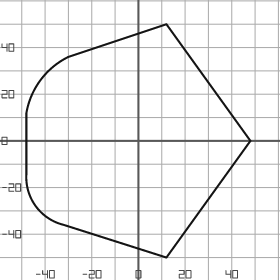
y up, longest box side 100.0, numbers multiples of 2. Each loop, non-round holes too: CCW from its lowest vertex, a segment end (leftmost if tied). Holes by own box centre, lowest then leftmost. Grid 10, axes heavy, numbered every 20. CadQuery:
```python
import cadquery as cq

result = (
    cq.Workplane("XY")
    .moveTo(12.0, -50.0)
    .lineTo(48.0, 0.0)
    .lineTo(12.0, 50.0)
    .lineTo(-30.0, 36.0)
    .threePointArc((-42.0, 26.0), (-48.0, 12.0))
    .lineTo(-48.0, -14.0)
    .threePointArc((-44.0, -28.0), (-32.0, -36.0))
    .close()
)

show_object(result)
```